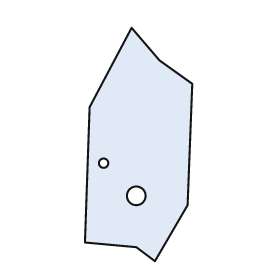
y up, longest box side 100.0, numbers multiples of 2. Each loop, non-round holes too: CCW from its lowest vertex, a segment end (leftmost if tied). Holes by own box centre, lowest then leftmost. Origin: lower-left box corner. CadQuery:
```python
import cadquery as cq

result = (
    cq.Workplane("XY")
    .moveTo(30.0, 0.0)
    .lineTo(44.0, 24.0)
    .lineTo(46.0, 76.0)
    .lineTo(32.0, 86.0)
    .lineTo(20.0, 100.0)
    .lineTo(2.0, 66.0)
    .lineTo(0.0, 8.0)
    .lineTo(22.0, 6.0)
    .close()
    .moveTo(22.0, 28.0)
    .circle(4.0)
    .moveTo(8.0, 42.0)
    .circle(2.0)
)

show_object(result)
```